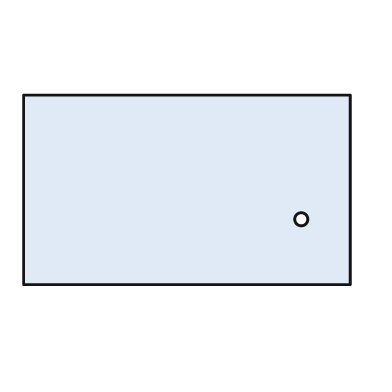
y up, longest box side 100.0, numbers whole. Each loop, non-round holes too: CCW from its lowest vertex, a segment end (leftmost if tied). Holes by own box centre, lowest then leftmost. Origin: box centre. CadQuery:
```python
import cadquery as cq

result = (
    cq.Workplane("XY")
    .moveTo(-50.0, -29.0)
    .lineTo(50.0, -29.0)
    .lineTo(50.0, 29.0)
    .lineTo(-50.0, 29.0)
    .close()
    .moveTo(35.0, -9.0)
    .circle(2.0)
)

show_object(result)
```